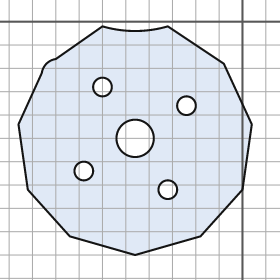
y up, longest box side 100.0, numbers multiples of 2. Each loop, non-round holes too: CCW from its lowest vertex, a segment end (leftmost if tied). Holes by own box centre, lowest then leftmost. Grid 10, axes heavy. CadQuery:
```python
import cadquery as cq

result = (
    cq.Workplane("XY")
    .moveTo(-46.0, -100.0)
    .lineTo(-18.0, -92.0)
    .lineTo(0.0, -72.0)
    .lineTo(4.0, -44.0)
    .lineTo(-8.0, -18.0)
    .lineTo(-32.0, -2.0)
    .threePointArc((-46.0, -4.0), (-60.0, -2.0))
    .lineTo(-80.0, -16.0)
    .threePointArc((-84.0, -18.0), (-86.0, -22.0))
    .lineTo(-96.0, -44.0)
    .lineTo(-92.0, -72.0)
    .lineTo(-74.0, -92.0)
    .close()
    .moveTo(-32.0, -72.0)
    .circle(4.0)
    .moveTo(-68.0, -64.0)
    .circle(4.0)
    .moveTo(-46.0, -50.0)
    .circle(8.0)
    .moveTo(-24.0, -36.0)
    .circle(4.0)
    .moveTo(-60.0, -28.0)
    .circle(4.0)
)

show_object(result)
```